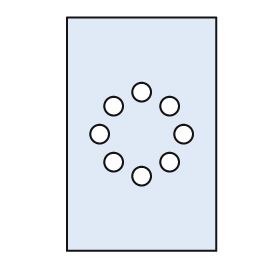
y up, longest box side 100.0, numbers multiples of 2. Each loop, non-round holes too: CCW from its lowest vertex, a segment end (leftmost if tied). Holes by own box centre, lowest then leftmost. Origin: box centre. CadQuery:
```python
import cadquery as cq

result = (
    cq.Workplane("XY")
    .moveTo(-32.0, -50.0)
    .lineTo(32.0, -50.0)
    .lineTo(32.0, 50.0)
    .lineTo(-32.0, 50.0)
    .close()
    .moveTo(0.0, -18.0)
    .circle(4.0)
    .moveTo(-12.0, -12.0)
    .circle(4.0)
    .moveTo(12.0, -12.0)
    .circle(4.0)
    .moveTo(-18.0, 0.0)
    .circle(4.0)
    .moveTo(18.0, 0.0)
    .circle(4.0)
    .moveTo(-12.0, 12.0)
    .circle(4.0)
    .moveTo(12.0, 12.0)
    .circle(4.0)
    .moveTo(0.0, 18.0)
    .circle(4.0)
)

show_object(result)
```